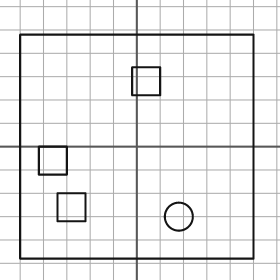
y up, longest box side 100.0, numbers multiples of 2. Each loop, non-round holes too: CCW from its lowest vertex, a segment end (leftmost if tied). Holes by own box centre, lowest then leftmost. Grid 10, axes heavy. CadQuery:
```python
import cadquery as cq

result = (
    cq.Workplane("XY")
    .moveTo(-50.0, -48.0)
    .lineTo(50.0, -48.0)
    .lineTo(50.0, 48.0)
    .lineTo(-50.0, 48.0)
    .close()
    .moveTo(18.0, -30.0)
    .circle(6.0)
    .moveTo(-34.0, -32.0)
    .lineTo(-22.0, -32.0)
    .lineTo(-22.0, -20.0)
    .lineTo(-34.0, -20.0)
    .close()
    .moveTo(-42.0, -12.0)
    .lineTo(-30.0, -12.0)
    .lineTo(-30.0, 0.0)
    .lineTo(-42.0, 0.0)
    .close()
    .moveTo(-2.0, 22.0)
    .lineTo(10.0, 22.0)
    .lineTo(10.0, 34.0)
    .lineTo(-2.0, 34.0)
    .close()
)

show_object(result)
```